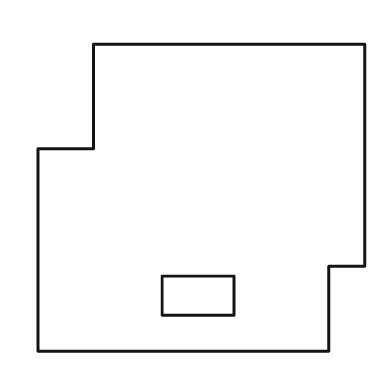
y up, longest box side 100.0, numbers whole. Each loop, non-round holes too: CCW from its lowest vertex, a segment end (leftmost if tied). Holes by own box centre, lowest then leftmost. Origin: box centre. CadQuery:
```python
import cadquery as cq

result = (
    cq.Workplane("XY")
    .moveTo(-50.0, -47.0)
    .lineTo(39.0, -47.0)
    .lineTo(39.0, -21.0)
    .lineTo(50.0, -21.0)
    .lineTo(50.0, 47.0)
    .lineTo(-33.0, 47.0)
    .lineTo(-33.0, 15.0)
    .lineTo(-50.0, 15.0)
    .close()
    .moveTo(-12.0, -36.0)
    .lineTo(10.0, -36.0)
    .lineTo(10.0, -24.0)
    .lineTo(-12.0, -24.0)
    .close()
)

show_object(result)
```